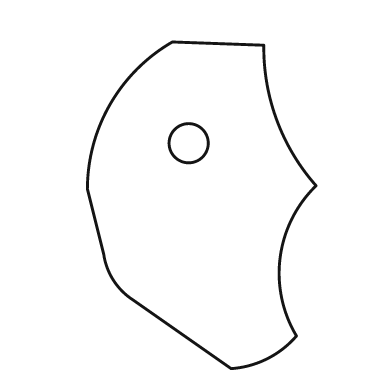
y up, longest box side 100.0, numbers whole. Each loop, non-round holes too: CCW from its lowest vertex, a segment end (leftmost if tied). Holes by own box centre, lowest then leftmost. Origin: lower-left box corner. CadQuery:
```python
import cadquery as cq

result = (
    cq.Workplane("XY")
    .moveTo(44.0, 0.0)
    .threePointArc((55.0, 3.0), (64.0, 10.0))
    .threePointArc((59.0, 34.0), (70.0, 56.0))
    .threePointArc((58.0, 76.0), (54.0, 99.0))
    .lineTo(26.0, 100.0)
    .threePointArc((7.0, 81.0), (0.0, 55.0))
    .lineTo(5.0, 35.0)
    .threePointArc((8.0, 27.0), (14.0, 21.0))
    .close()
    .moveTo(31.0, 69.0)
    .circle(6.0)
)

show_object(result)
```